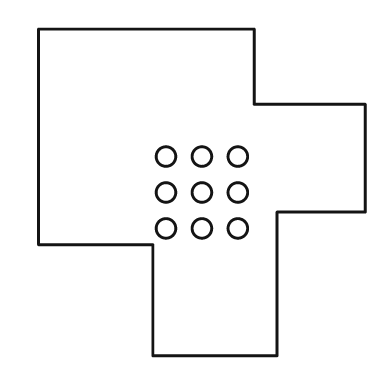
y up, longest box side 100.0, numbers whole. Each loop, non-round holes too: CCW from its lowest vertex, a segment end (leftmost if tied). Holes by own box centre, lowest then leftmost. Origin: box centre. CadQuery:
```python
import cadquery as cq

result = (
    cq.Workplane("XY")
    .moveTo(-15.0, -50.0)
    .lineTo(23.0, -50.0)
    .lineTo(23.0, -6.0)
    .lineTo(50.0, -6.0)
    .lineTo(50.0, 27.0)
    .lineTo(16.0, 27.0)
    .lineTo(16.0, 50.0)
    .lineTo(-50.0, 50.0)
    .lineTo(-50.0, -16.0)
    .lineTo(-15.0, -16.0)
    .close()
    .moveTo(-11.0, -11.0)
    .circle(3.0)
    .moveTo(0.0, -11.0)
    .circle(3.0)
    .moveTo(11.0, -11.0)
    .circle(3.0)
    .moveTo(-11.0, 0.0)
    .circle(3.0)
    .moveTo(0.0, 0.0)
    .circle(3.0)
    .moveTo(11.0, 0.0)
    .circle(3.0)
    .moveTo(-11.0, 11.0)
    .circle(3.0)
    .moveTo(0.0, 11.0)
    .circle(3.0)
    .moveTo(11.0, 11.0)
    .circle(3.0)
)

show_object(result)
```